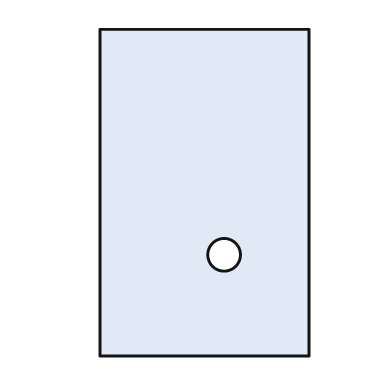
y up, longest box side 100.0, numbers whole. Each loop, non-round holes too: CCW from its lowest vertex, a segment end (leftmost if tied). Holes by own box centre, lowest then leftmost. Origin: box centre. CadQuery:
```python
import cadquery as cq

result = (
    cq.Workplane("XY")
    .moveTo(-32.0, -50.0)
    .lineTo(32.0, -50.0)
    .lineTo(32.0, 50.0)
    .lineTo(-32.0, 50.0)
    .close()
    .moveTo(6.0, -19.0)
    .circle(5.0)
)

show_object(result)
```